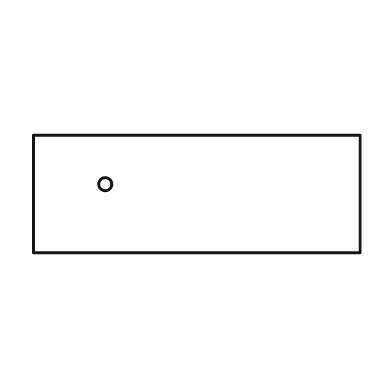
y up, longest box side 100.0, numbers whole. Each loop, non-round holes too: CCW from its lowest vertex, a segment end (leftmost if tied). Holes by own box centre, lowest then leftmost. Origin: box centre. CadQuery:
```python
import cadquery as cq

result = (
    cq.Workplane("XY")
    .moveTo(-50.0, -18.0)
    .lineTo(50.0, -18.0)
    .lineTo(50.0, 18.0)
    .lineTo(-50.0, 18.0)
    .close()
    .moveTo(-28.0, 3.0)
    .circle(2.0)
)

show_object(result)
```